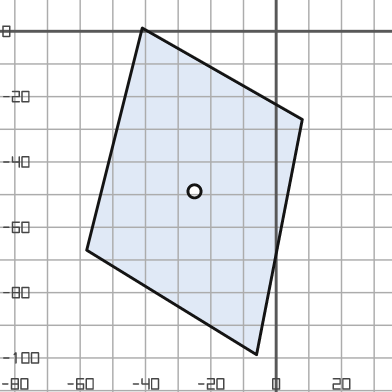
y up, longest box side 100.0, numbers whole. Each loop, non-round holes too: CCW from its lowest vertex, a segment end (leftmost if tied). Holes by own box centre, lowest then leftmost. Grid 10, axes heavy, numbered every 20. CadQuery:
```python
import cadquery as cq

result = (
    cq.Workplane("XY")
    .moveTo(-6.0, -99.0)
    .lineTo(8.0, -27.0)
    .lineTo(-41.0, 1.0)
    .lineTo(-58.0, -67.0)
    .close()
    .moveTo(-25.0, -49.0)
    .circle(2.0)
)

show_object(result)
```